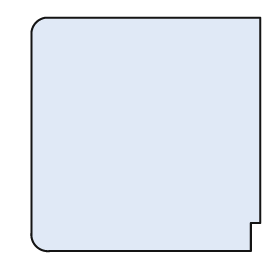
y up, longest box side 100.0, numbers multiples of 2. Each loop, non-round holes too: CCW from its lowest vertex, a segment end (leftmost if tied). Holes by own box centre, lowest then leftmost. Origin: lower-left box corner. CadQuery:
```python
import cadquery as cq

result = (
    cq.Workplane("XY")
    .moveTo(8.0, 0.0)
    .lineTo(94.0, 0.0)
    .lineTo(94.0, 12.0)
    .lineTo(98.0, 12.0)
    .lineTo(98.0, 100.0)
    .lineTo(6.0, 100.0)
    .threePointArc((2.0, 98.0), (0.0, 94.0))
    .lineTo(0.0, 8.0)
    .threePointArc((2.0, 2.0), (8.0, 0.0))
    .close()
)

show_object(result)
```